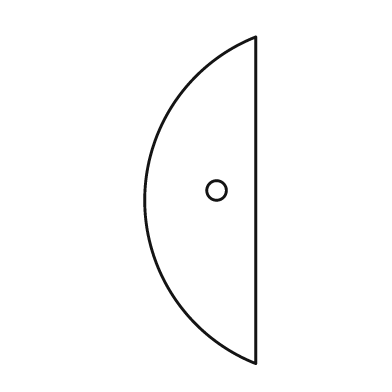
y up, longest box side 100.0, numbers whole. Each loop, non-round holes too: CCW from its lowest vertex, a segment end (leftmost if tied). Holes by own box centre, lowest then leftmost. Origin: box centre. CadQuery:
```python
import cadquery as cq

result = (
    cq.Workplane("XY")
    .moveTo(17.0, -50.0)
    .lineTo(17.0, 50.0)
    .threePointArc((-17.0, 0.0), (17.0, -50.0))
    .close()
    .moveTo(5.0, 3.0)
    .circle(3.0)
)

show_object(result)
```